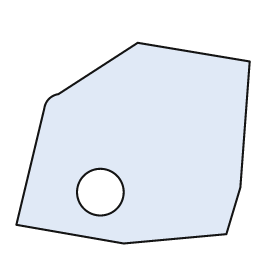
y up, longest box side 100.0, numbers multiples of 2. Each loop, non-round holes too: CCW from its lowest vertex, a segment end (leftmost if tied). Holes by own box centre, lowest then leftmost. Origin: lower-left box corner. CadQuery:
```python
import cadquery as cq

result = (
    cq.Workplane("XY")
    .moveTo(46.0, 0.0)
    .lineTo(90.0, 4.0)
    .lineTo(96.0, 24.0)
    .lineTo(100.0, 78.0)
    .lineTo(52.0, 86.0)
    .lineTo(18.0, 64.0)
    .threePointArc((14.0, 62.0), (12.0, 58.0))
    .lineTo(0.0, 8.0)
    .close()
    .moveTo(36.0, 22.0)
    .circle(10.0)
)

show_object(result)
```